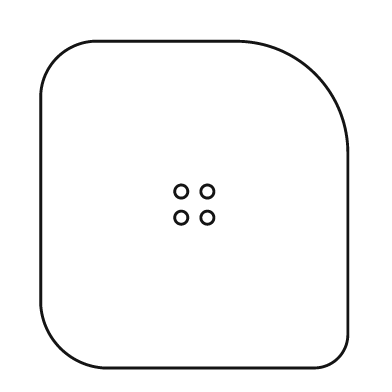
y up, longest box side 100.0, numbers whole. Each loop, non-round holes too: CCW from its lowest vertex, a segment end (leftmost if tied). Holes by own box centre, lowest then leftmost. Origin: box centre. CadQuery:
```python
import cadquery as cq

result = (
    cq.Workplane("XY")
    .moveTo(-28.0, -50.0)
    .lineTo(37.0, -50.0)
    .threePointArc((44.0, -47.0), (47.0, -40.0))
    .lineTo(47.0, 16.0)
    .threePointArc((37.0, 40.0), (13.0, 50.0))
    .lineTo(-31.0, 50.0)
    .threePointArc((-42.0, 45.0), (-47.0, 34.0))
    .lineTo(-47.0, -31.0)
    .threePointArc((-41.0, -44.0), (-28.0, -50.0))
    .close()
    .moveTo(-4.0, -4.0)
    .circle(2.0)
    .moveTo(4.0, -4.0)
    .circle(2.0)
    .moveTo(-4.0, 4.0)
    .circle(2.0)
    .moveTo(4.0, 4.0)
    .circle(2.0)
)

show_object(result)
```